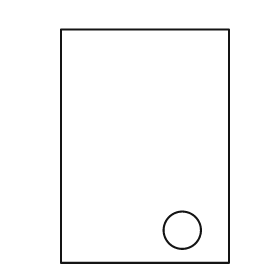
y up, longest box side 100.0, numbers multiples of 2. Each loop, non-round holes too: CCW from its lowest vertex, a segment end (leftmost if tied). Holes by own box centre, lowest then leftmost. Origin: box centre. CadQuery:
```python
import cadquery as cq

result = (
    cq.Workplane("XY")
    .moveTo(-36.0, -50.0)
    .lineTo(36.0, -50.0)
    .lineTo(36.0, 50.0)
    .lineTo(-36.0, 50.0)
    .close()
    .moveTo(16.0, -36.0)
    .circle(8.0)
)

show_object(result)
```